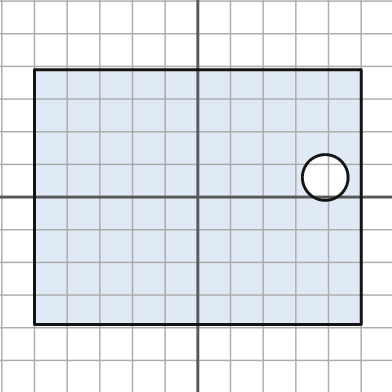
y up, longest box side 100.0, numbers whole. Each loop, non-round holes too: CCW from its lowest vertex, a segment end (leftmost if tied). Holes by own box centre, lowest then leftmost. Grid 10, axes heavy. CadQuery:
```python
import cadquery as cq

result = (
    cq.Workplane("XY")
    .moveTo(-50.0, -39.0)
    .lineTo(50.0, -39.0)
    .lineTo(50.0, 39.0)
    .lineTo(-50.0, 39.0)
    .close()
    .moveTo(39.0, 6.0)
    .circle(7.0)
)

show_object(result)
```